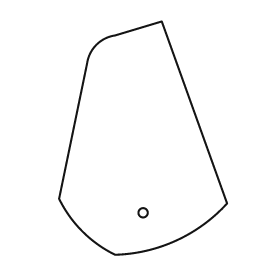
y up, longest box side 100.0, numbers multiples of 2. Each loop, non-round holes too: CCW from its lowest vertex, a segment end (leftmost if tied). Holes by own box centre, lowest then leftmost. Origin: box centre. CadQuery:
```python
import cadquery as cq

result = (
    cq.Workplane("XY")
    .moveTo(-12.0, -50.0)
    .threePointArc((14.0, -44.0), (36.0, -28.0))
    .lineTo(8.0, 50.0)
    .lineTo(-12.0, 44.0)
    .threePointArc((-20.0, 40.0), (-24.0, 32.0))
    .lineTo(-36.0, -26.0)
    .threePointArc((-26.0, -40.0), (-12.0, -50.0))
    .close()
    .moveTo(0.0, -32.0)
    .circle(2.0)
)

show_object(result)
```